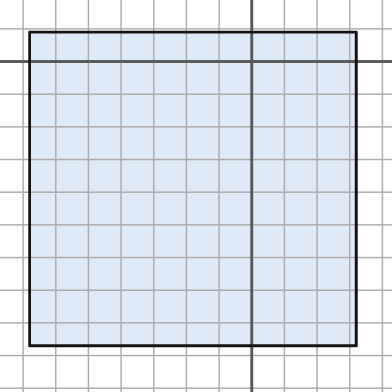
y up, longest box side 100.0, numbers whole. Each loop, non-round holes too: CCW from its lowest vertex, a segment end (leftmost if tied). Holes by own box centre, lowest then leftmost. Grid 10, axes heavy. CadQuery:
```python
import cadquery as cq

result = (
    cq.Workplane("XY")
    .moveTo(-68.0, -87.0)
    .lineTo(32.0, -87.0)
    .lineTo(32.0, 9.0)
    .lineTo(-68.0, 9.0)
    .close()
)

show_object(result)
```